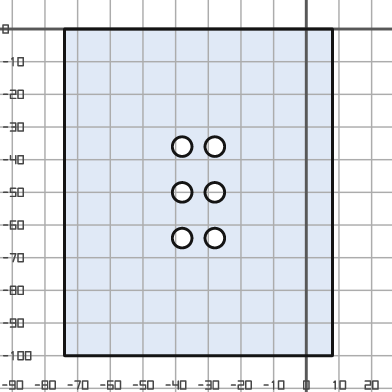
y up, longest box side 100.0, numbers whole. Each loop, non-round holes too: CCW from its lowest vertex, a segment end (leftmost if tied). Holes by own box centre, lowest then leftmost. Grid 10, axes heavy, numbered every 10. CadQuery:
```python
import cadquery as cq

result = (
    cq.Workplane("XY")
    .moveTo(-74.0, -100.0)
    .lineTo(8.0, -100.0)
    .lineTo(8.0, 0.0)
    .lineTo(-74.0, 0.0)
    .close()
    .moveTo(-38.0, -64.0)
    .circle(3.0)
    .moveTo(-28.0, -64.0)
    .circle(3.0)
    .moveTo(-38.0, -50.0)
    .circle(3.0)
    .moveTo(-28.0, -50.0)
    .circle(3.0)
    .moveTo(-38.0, -36.0)
    .circle(3.0)
    .moveTo(-28.0, -36.0)
    .circle(3.0)
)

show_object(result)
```